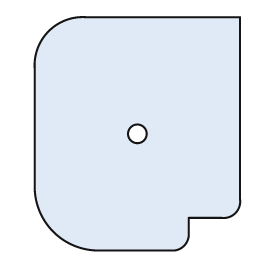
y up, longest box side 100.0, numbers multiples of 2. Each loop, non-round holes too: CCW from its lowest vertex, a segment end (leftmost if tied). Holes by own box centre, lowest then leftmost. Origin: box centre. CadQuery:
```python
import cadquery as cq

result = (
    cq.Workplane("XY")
    .moveTo(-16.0, -50.0)
    .lineTo(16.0, -50.0)
    .threePointArc((20.0, -48.0), (22.0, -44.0))
    .lineTo(22.0, -36.0)
    .lineTo(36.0, -36.0)
    .threePointArc((42.0, -34.0), (44.0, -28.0))
    .lineTo(44.0, 50.0)
    .lineTo(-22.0, 50.0)
    .threePointArc((-38.0, 44.0), (-44.0, 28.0))
    .lineTo(-44.0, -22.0)
    .threePointArc((-36.0, -42.0), (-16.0, -50.0))
    .close()
    .moveTo(0.0, 0.0)
    .circle(4.0)
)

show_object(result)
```